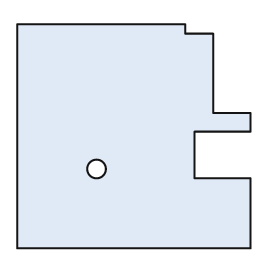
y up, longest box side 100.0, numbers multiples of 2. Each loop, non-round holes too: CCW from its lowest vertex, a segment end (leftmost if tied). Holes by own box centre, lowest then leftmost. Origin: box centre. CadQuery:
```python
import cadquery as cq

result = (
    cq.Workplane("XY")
    .moveTo(-50.0, -48.0)
    .lineTo(50.0, -48.0)
    .lineTo(50.0, -18.0)
    .lineTo(26.0, -18.0)
    .lineTo(26.0, 2.0)
    .lineTo(50.0, 2.0)
    .lineTo(50.0, 10.0)
    .lineTo(34.0, 10.0)
    .lineTo(34.0, 44.0)
    .lineTo(22.0, 44.0)
    .lineTo(22.0, 48.0)
    .lineTo(-50.0, 48.0)
    .close()
    .moveTo(-16.0, -14.0)
    .circle(4.0)
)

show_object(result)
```